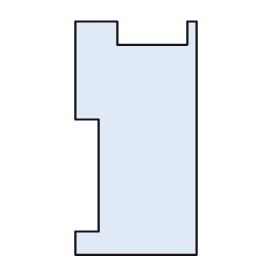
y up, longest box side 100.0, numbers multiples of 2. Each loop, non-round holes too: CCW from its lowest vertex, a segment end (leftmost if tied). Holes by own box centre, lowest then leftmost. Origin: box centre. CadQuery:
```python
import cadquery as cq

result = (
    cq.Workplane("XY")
    .moveTo(-26.0, -50.0)
    .lineTo(26.0, -50.0)
    .lineTo(26.0, 50.0)
    .lineTo(22.0, 50.0)
    .lineTo(22.0, 40.0)
    .lineTo(-8.0, 40.0)
    .lineTo(-8.0, 50.0)
    .lineTo(-26.0, 50.0)
    .lineTo(-26.0, 8.0)
    .lineTo(-16.0, 8.0)
    .lineTo(-16.0, -40.0)
    .lineTo(-26.0, -40.0)
    .close()
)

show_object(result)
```